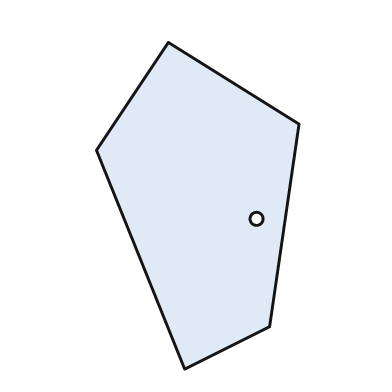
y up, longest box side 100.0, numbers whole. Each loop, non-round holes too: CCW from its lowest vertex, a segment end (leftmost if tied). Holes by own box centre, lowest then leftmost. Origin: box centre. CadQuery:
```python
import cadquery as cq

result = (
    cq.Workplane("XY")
    .moveTo(-4.0, -50.0)
    .lineTo(22.0, -37.0)
    .lineTo(31.0, 25.0)
    .lineTo(-9.0, 50.0)
    .lineTo(-31.0, 17.0)
    .close()
    .moveTo(18.0, -4.0)
    .circle(2.0)
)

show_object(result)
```